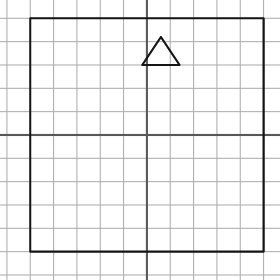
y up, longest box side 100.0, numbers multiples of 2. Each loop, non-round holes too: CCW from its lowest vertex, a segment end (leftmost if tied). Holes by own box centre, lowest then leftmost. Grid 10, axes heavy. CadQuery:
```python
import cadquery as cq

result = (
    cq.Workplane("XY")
    .moveTo(-50.0, -50.0)
    .lineTo(50.0, -50.0)
    .lineTo(50.0, 50.0)
    .lineTo(-50.0, 50.0)
    .close()
    .moveTo(-2.0, 30.0)
    .lineTo(14.0, 30.0)
    .lineTo(6.0, 42.0)
    .close()
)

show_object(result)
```